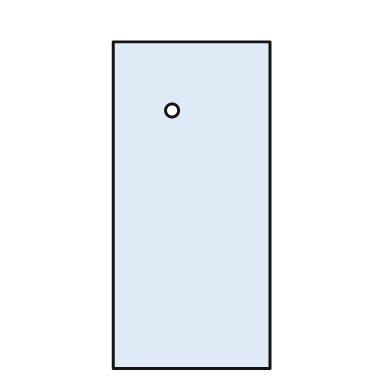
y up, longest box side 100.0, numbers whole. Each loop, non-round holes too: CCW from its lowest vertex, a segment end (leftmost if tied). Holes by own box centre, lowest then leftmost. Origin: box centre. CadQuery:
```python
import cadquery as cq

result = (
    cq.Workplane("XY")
    .moveTo(-24.0, -50.0)
    .lineTo(24.0, -50.0)
    .lineTo(24.0, 50.0)
    .lineTo(-24.0, 50.0)
    .close()
    .moveTo(-6.0, 29.0)
    .circle(2.0)
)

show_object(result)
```